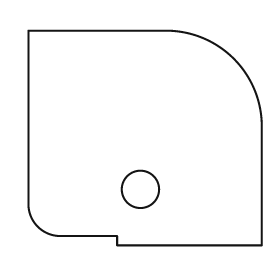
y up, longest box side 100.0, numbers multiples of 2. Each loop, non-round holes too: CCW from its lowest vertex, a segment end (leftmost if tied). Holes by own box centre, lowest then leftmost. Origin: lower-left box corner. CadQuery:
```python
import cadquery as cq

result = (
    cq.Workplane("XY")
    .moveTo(38.0, 0.0)
    .lineTo(100.0, 0.0)
    .lineTo(100.0, 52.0)
    .threePointArc((88.0, 80.0), (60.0, 92.0))
    .lineTo(0.0, 92.0)
    .lineTo(0.0, 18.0)
    .threePointArc((4.0, 8.0), (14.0, 4.0))
    .lineTo(38.0, 4.0)
    .close()
    .moveTo(48.0, 24.0)
    .circle(8.0)
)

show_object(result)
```